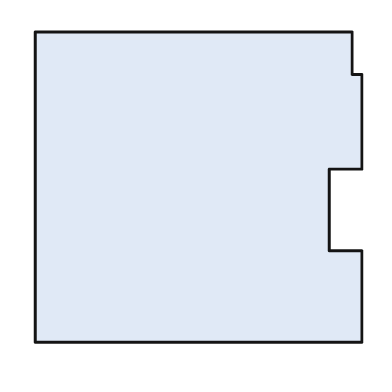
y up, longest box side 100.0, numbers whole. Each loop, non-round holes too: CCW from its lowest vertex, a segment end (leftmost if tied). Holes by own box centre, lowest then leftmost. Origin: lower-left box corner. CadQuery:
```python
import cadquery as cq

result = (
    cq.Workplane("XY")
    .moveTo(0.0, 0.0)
    .lineTo(100.0, 0.0)
    .lineTo(100.0, 28.0)
    .lineTo(90.0, 28.0)
    .lineTo(90.0, 53.0)
    .lineTo(100.0, 53.0)
    .lineTo(100.0, 82.0)
    .lineTo(97.0, 82.0)
    .lineTo(97.0, 95.0)
    .lineTo(0.0, 95.0)
    .close()
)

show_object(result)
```